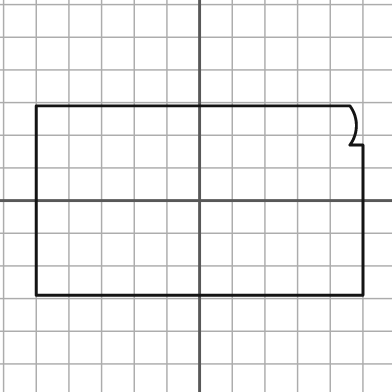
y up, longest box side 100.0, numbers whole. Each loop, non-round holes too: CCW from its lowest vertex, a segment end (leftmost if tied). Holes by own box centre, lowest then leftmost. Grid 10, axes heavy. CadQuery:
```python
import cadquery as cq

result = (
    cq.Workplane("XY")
    .moveTo(-50.0, -29.0)
    .lineTo(50.0, -29.0)
    .lineTo(50.0, 17.0)
    .lineTo(46.0, 17.0)
    .threePointArc((48.0, 23.0), (46.0, 29.0))
    .lineTo(-50.0, 29.0)
    .close()
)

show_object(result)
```